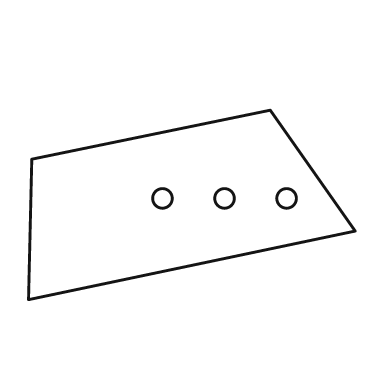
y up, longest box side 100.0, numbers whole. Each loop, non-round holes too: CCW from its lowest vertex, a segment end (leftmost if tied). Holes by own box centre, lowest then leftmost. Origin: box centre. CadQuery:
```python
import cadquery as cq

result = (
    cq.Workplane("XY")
    .moveTo(-50.0, -29.0)
    .lineTo(50.0, -8.0)
    .lineTo(24.0, 29.0)
    .lineTo(-49.0, 14.0)
    .close()
    .moveTo(-9.0, 2.0)
    .circle(3.0)
    .moveTo(10.0, 2.0)
    .circle(3.0)
    .moveTo(29.0, 2.0)
    .circle(3.0)
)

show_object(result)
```